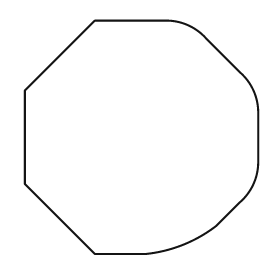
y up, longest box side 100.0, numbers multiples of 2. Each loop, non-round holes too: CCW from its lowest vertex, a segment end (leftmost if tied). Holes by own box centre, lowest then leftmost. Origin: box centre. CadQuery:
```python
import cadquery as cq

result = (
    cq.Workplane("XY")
    .moveTo(-20.0, -50.0)
    .lineTo(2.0, -50.0)
    .threePointArc((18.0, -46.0), (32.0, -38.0))
    .lineTo(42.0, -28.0)
    .threePointArc((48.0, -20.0), (50.0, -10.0))
    .lineTo(50.0, 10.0)
    .threePointArc((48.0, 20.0), (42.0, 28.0))
    .lineTo(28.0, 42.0)
    .threePointArc((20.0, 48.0), (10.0, 50.0))
    .lineTo(-20.0, 50.0)
    .lineTo(-50.0, 20.0)
    .lineTo(-50.0, -20.0)
    .close()
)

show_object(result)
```